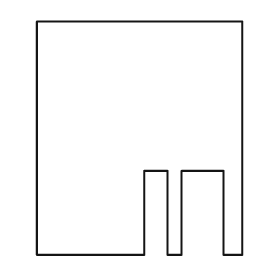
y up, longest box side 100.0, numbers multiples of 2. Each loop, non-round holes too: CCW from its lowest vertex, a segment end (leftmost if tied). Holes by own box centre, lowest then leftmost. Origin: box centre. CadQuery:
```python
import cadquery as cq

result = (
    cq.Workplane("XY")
    .moveTo(-44.0, -50.0)
    .lineTo(2.0, -50.0)
    .lineTo(2.0, -14.0)
    .lineTo(12.0, -14.0)
    .lineTo(12.0, -50.0)
    .lineTo(18.0, -50.0)
    .lineTo(18.0, -14.0)
    .lineTo(36.0, -14.0)
    .lineTo(36.0, -50.0)
    .lineTo(44.0, -50.0)
    .lineTo(44.0, 50.0)
    .lineTo(-44.0, 50.0)
    .close()
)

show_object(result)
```